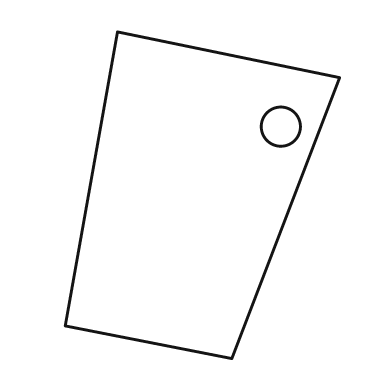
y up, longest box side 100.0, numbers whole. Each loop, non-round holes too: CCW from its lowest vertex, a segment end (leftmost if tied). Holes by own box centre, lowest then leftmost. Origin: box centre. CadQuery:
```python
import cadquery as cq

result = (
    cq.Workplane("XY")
    .moveTo(9.0, -50.0)
    .lineTo(42.0, 36.0)
    .lineTo(-26.0, 50.0)
    .lineTo(-42.0, -40.0)
    .close()
    .moveTo(24.0, 21.0)
    .circle(6.0)
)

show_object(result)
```